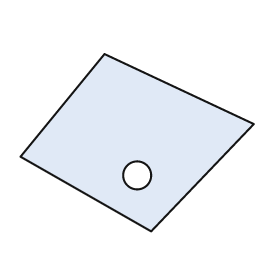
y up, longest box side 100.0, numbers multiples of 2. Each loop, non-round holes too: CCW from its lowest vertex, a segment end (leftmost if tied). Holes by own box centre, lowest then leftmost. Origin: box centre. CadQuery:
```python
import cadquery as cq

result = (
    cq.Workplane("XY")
    .moveTo(6.0, -38.0)
    .lineTo(50.0, 8.0)
    .lineTo(-14.0, 38.0)
    .lineTo(-50.0, -6.0)
    .close()
    .moveTo(0.0, -14.0)
    .circle(6.0)
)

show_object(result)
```